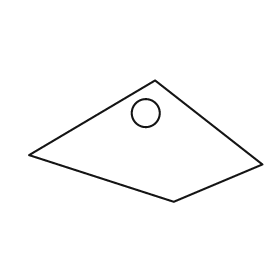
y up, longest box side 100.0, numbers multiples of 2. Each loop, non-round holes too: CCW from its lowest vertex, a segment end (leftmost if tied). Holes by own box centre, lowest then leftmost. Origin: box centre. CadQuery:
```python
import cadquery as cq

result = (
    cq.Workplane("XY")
    .moveTo(12.0, -26.0)
    .lineTo(50.0, -10.0)
    .lineTo(4.0, 26.0)
    .lineTo(-50.0, -6.0)
    .close()
    .moveTo(0.0, 12.0)
    .circle(6.0)
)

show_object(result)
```